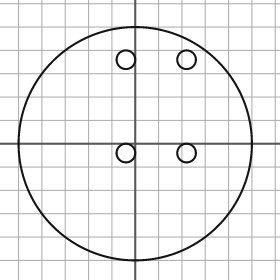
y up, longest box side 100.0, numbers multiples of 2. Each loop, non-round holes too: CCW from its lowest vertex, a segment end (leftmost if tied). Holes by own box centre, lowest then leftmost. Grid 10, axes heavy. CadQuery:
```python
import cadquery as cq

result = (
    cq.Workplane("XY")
    .moveTo(0.0, 0.0)
    .circle(50.0)
    .moveTo(-4.0, -4.0)
    .circle(4.0)
    .moveTo(22.0, -4.0)
    .circle(4.0)
    .moveTo(-4.0, 36.0)
    .circle(4.0)
    .moveTo(22.0, 36.0)
    .circle(4.0)
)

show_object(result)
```